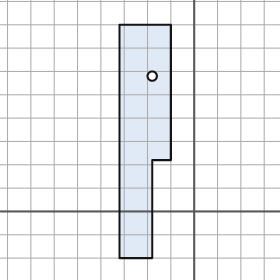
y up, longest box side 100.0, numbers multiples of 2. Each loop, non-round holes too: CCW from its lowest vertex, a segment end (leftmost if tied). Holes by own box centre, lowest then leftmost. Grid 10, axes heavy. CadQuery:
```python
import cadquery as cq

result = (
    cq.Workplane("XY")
    .moveTo(-32.0, -20.0)
    .lineTo(-18.0, -20.0)
    .lineTo(-18.0, 22.0)
    .lineTo(-10.0, 22.0)
    .lineTo(-10.0, 80.0)
    .lineTo(-32.0, 80.0)
    .close()
    .moveTo(-18.0, 58.0)
    .circle(2.0)
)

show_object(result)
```